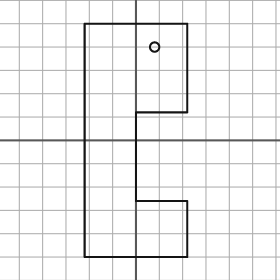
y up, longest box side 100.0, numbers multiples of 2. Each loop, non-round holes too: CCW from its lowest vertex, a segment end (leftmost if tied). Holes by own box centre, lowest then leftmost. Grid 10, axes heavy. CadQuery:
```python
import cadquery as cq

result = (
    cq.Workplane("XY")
    .moveTo(-22.0, -50.0)
    .lineTo(22.0, -50.0)
    .lineTo(22.0, -26.0)
    .lineTo(0.0, -26.0)
    .lineTo(0.0, 12.0)
    .lineTo(22.0, 12.0)
    .lineTo(22.0, 50.0)
    .lineTo(-22.0, 50.0)
    .close()
    .moveTo(8.0, 40.0)
    .circle(2.0)
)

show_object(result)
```